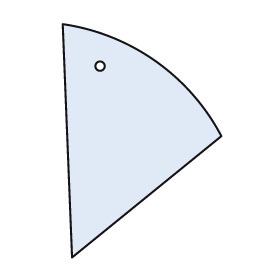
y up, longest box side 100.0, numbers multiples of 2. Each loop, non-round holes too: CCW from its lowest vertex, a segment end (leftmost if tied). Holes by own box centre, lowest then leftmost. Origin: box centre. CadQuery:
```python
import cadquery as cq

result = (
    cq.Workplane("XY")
    .moveTo(-30.0, -50.0)
    .lineTo(34.0, 2.0)
    .threePointArc((6.0, 34.0), (-34.0, 50.0))
    .close()
    .moveTo(-18.0, 32.0)
    .circle(2.0)
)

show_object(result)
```